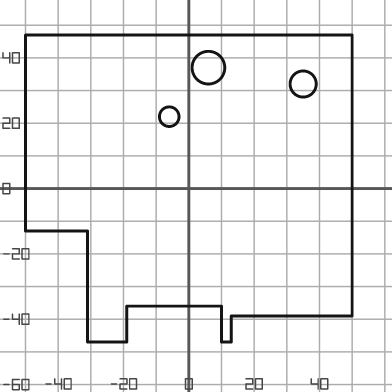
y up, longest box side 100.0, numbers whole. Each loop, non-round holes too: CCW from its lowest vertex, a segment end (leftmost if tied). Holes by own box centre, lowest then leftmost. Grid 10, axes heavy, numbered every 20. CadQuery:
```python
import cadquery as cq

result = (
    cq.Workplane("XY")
    .moveTo(-31.0, -47.0)
    .lineTo(-19.0, -47.0)
    .lineTo(-19.0, -36.0)
    .lineTo(10.0, -36.0)
    .lineTo(10.0, -47.0)
    .lineTo(13.0, -47.0)
    .lineTo(13.0, -39.0)
    .lineTo(50.0, -39.0)
    .lineTo(50.0, 47.0)
    .lineTo(-50.0, 47.0)
    .lineTo(-50.0, -13.0)
    .lineTo(-31.0, -13.0)
    .close()
    .moveTo(-6.0, 22.0)
    .circle(3.0)
    .moveTo(35.0, 32.0)
    .circle(4.0)
    .moveTo(6.0, 37.0)
    .circle(5.0)
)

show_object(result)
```